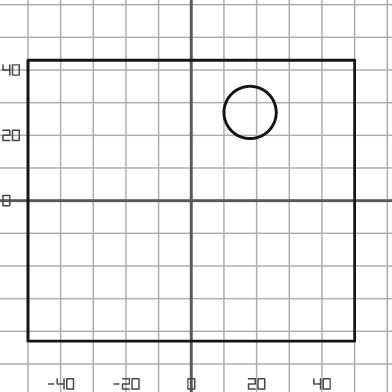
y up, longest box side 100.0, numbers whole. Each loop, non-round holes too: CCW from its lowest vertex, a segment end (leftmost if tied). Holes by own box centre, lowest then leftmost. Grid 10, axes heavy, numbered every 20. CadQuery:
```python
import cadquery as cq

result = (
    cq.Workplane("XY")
    .moveTo(-50.0, -43.0)
    .lineTo(50.0, -43.0)
    .lineTo(50.0, 43.0)
    .lineTo(-50.0, 43.0)
    .close()
    .moveTo(18.0, 27.0)
    .circle(8.0)
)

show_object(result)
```